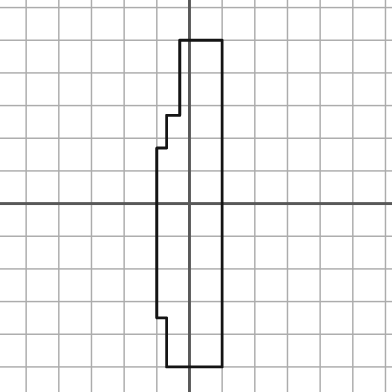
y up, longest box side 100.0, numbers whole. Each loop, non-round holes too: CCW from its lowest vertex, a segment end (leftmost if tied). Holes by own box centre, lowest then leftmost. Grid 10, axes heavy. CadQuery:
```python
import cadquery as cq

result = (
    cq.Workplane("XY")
    .moveTo(-7.0, -50.0)
    .lineTo(10.0, -50.0)
    .lineTo(10.0, 50.0)
    .lineTo(-3.0, 50.0)
    .lineTo(-3.0, 27.0)
    .lineTo(-7.0, 27.0)
    .lineTo(-7.0, 17.0)
    .lineTo(-10.0, 17.0)
    .lineTo(-10.0, -35.0)
    .lineTo(-7.0, -35.0)
    .close()
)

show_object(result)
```